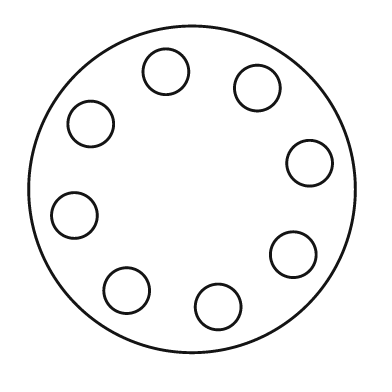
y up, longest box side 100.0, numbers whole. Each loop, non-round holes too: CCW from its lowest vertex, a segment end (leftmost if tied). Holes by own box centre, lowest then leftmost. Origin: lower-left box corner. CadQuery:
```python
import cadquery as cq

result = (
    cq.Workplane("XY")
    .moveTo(50.0, 50.0)
    .circle(50.0)
    .moveTo(58.0, 14.0)
    .circle(7.0)
    .moveTo(30.0, 19.0)
    .circle(7.0)
    .moveTo(81.0, 30.0)
    .circle(7.0)
    .moveTo(14.0, 42.0)
    .circle(7.0)
    .moveTo(86.0, 58.0)
    .circle(7.0)
    .moveTo(19.0, 70.0)
    .circle(7.0)
    .moveTo(70.0, 81.0)
    .circle(7.0)
    .moveTo(42.0, 86.0)
    .circle(7.0)
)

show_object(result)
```